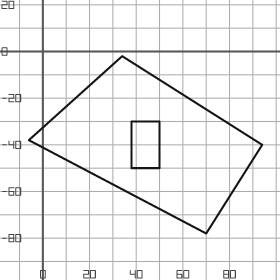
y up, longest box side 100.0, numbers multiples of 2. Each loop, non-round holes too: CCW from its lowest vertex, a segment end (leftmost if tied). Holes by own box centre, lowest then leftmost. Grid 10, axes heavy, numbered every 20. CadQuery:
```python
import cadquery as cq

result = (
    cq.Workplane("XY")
    .moveTo(70.0, -78.0)
    .lineTo(94.0, -40.0)
    .lineTo(34.0, -2.0)
    .lineTo(-6.0, -38.0)
    .close()
    .moveTo(38.0, -50.0)
    .lineTo(50.0, -50.0)
    .lineTo(50.0, -30.0)
    .lineTo(38.0, -30.0)
    .close()
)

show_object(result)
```